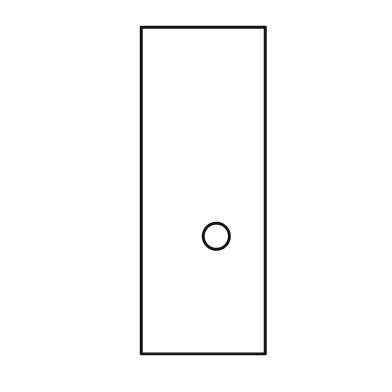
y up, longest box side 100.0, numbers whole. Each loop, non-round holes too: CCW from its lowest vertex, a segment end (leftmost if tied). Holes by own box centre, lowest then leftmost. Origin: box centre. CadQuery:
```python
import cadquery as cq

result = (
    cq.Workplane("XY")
    .moveTo(-19.0, -50.0)
    .lineTo(19.0, -50.0)
    .lineTo(19.0, 50.0)
    .lineTo(-19.0, 50.0)
    .close()
    .moveTo(4.0, -14.0)
    .circle(4.0)
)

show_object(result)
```